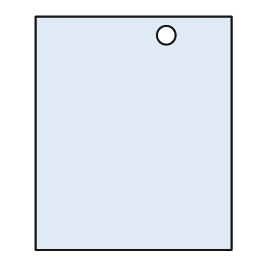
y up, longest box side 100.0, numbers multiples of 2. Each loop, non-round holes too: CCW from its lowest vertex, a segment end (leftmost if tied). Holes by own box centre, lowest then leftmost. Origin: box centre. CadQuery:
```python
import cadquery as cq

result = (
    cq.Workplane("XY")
    .moveTo(-42.0, -50.0)
    .lineTo(42.0, -50.0)
    .lineTo(42.0, 50.0)
    .lineTo(-42.0, 50.0)
    .close()
    .moveTo(14.0, 42.0)
    .circle(4.0)
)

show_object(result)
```